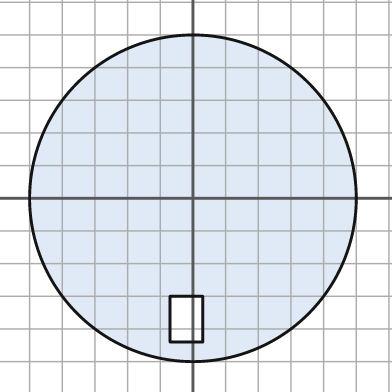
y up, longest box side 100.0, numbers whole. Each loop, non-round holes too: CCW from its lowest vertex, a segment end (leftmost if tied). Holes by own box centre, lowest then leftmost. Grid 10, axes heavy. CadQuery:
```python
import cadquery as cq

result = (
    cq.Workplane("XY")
    .moveTo(0.0, 0.0)
    .circle(50.0)
    .moveTo(-7.0, -44.0)
    .lineTo(3.0, -44.0)
    .lineTo(3.0, -30.0)
    .lineTo(-7.0, -30.0)
    .close()
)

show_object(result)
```